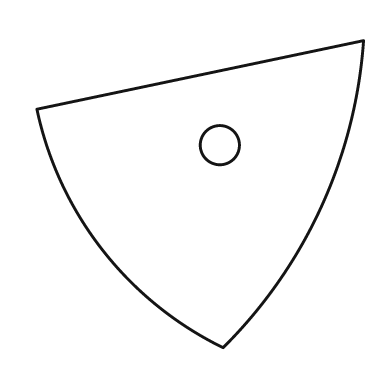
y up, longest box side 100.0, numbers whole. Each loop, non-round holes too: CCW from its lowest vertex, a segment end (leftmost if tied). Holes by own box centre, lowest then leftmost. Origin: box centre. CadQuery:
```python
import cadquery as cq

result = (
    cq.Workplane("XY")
    .moveTo(7.0, -47.0)
    .threePointArc((37.0, -4.0), (50.0, 47.0))
    .lineTo(-50.0, 26.0)
    .threePointArc((-30.0, -17.0), (7.0, -47.0))
    .close()
    .moveTo(6.0, 15.0)
    .circle(6.0)
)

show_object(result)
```